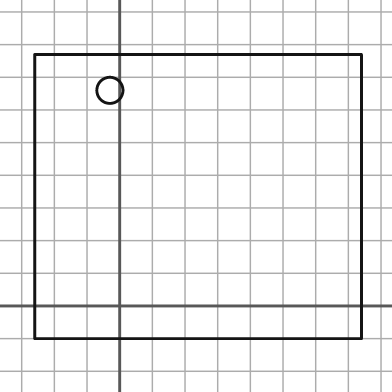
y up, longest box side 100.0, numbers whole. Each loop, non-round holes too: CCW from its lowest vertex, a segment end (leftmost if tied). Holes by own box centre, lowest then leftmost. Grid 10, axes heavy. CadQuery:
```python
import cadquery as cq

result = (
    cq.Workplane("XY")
    .moveTo(-26.0, -10.0)
    .lineTo(74.0, -10.0)
    .lineTo(74.0, 77.0)
    .lineTo(-26.0, 77.0)
    .close()
    .moveTo(-3.0, 66.0)
    .circle(4.0)
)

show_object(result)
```